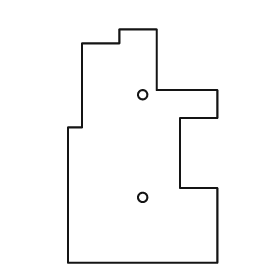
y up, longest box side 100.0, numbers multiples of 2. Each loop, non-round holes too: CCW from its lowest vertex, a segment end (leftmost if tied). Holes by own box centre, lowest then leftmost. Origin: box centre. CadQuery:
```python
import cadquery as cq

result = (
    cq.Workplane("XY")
    .moveTo(-32.0, -50.0)
    .lineTo(32.0, -50.0)
    .lineTo(32.0, -18.0)
    .lineTo(16.0, -18.0)
    .lineTo(16.0, 12.0)
    .lineTo(32.0, 12.0)
    .lineTo(32.0, 24.0)
    .lineTo(6.0, 24.0)
    .lineTo(6.0, 50.0)
    .lineTo(-10.0, 50.0)
    .lineTo(-10.0, 44.0)
    .lineTo(-26.0, 44.0)
    .lineTo(-26.0, 8.0)
    .lineTo(-32.0, 8.0)
    .close()
    .moveTo(0.0, -22.0)
    .circle(2.0)
    .moveTo(0.0, 22.0)
    .circle(2.0)
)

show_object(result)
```